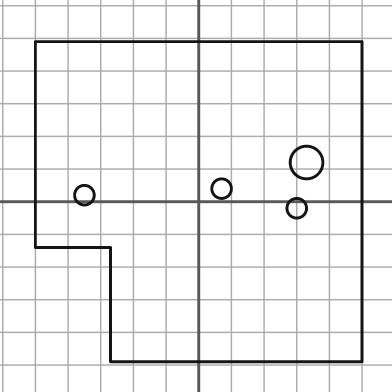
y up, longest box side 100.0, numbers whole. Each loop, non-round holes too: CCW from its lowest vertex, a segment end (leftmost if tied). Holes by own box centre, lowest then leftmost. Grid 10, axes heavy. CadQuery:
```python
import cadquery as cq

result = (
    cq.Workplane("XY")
    .moveTo(-27.0, -49.0)
    .lineTo(50.0, -49.0)
    .lineTo(50.0, 49.0)
    .lineTo(-50.0, 49.0)
    .lineTo(-50.0, -14.0)
    .lineTo(-27.0, -14.0)
    .close()
    .moveTo(30.0, -2.0)
    .circle(3.0)
    .moveTo(-35.0, 2.0)
    .circle(3.0)
    .moveTo(7.0, 4.0)
    .circle(3.0)
    .moveTo(33.0, 12.0)
    .circle(5.0)
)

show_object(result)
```